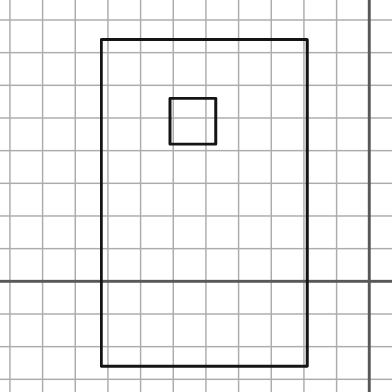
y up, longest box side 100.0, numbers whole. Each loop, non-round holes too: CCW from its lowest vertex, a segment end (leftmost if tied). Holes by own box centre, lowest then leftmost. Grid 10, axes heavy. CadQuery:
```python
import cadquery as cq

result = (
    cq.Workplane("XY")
    .moveTo(-82.0, -26.0)
    .lineTo(-19.0, -26.0)
    .lineTo(-19.0, 74.0)
    .lineTo(-82.0, 74.0)
    .close()
    .moveTo(-61.0, 42.0)
    .lineTo(-47.0, 42.0)
    .lineTo(-47.0, 56.0)
    .lineTo(-61.0, 56.0)
    .close()
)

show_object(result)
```